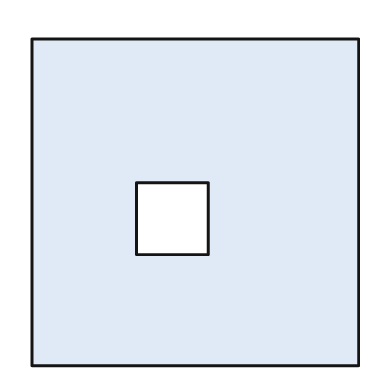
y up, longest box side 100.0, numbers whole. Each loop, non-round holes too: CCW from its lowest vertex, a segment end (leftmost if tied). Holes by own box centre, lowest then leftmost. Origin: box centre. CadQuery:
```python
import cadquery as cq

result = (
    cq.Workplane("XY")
    .moveTo(-50.0, -50.0)
    .lineTo(50.0, -50.0)
    .lineTo(50.0, 50.0)
    .lineTo(-50.0, 50.0)
    .close()
    .moveTo(-18.0, -16.0)
    .lineTo(4.0, -16.0)
    .lineTo(4.0, 6.0)
    .lineTo(-18.0, 6.0)
    .close()
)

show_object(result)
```